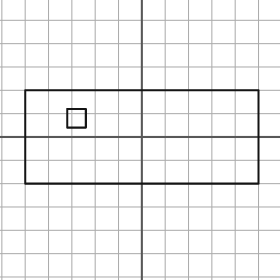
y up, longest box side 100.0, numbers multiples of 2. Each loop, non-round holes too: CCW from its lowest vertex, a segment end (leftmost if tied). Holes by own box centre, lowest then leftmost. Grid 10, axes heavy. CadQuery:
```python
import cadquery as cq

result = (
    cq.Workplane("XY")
    .moveTo(-50.0, -20.0)
    .lineTo(50.0, -20.0)
    .lineTo(50.0, 20.0)
    .lineTo(-50.0, 20.0)
    .close()
    .moveTo(-32.0, 4.0)
    .lineTo(-24.0, 4.0)
    .lineTo(-24.0, 12.0)
    .lineTo(-32.0, 12.0)
    .close()
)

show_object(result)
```